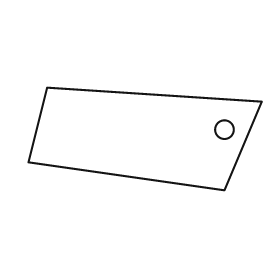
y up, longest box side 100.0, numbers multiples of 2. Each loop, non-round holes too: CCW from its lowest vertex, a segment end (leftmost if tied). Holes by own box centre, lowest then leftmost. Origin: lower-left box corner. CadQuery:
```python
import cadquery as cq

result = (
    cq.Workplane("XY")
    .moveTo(84.0, 0.0)
    .lineTo(100.0, 38.0)
    .lineTo(8.0, 44.0)
    .lineTo(0.0, 12.0)
    .close()
    .moveTo(84.0, 26.0)
    .circle(4.0)
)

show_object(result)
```